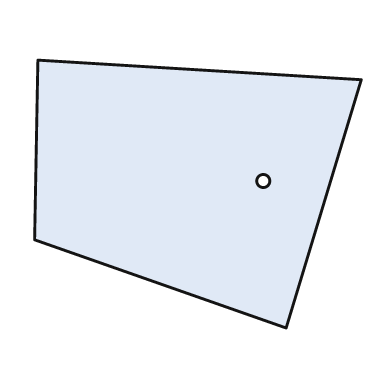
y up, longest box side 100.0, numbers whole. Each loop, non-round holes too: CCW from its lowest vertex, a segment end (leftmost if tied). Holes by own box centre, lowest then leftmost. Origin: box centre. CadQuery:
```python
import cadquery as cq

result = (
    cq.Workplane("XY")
    .moveTo(27.0, -41.0)
    .lineTo(50.0, 35.0)
    .lineTo(-49.0, 41.0)
    .lineTo(-50.0, -14.0)
    .close()
    .moveTo(20.0, 4.0)
    .circle(2.0)
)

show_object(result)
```